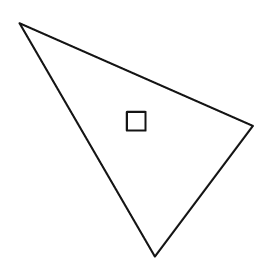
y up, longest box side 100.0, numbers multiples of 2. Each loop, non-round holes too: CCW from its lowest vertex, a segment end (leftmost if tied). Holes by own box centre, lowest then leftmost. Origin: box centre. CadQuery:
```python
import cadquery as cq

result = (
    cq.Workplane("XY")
    .moveTo(8.0, -50.0)
    .lineTo(50.0, 6.0)
    .lineTo(-50.0, 50.0)
    .close()
    .moveTo(-4.0, 4.0)
    .lineTo(4.0, 4.0)
    .lineTo(4.0, 12.0)
    .lineTo(-4.0, 12.0)
    .close()
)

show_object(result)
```